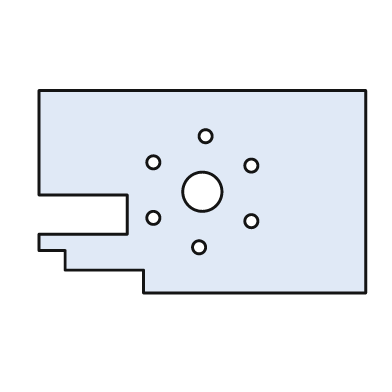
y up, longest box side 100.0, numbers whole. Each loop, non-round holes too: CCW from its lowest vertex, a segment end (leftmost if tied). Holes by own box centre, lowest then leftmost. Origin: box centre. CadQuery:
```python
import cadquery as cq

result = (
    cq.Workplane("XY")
    .moveTo(-18.0, -31.0)
    .lineTo(50.0, -31.0)
    .lineTo(50.0, 31.0)
    .lineTo(-50.0, 31.0)
    .lineTo(-50.0, -1.0)
    .lineTo(-23.0, -1.0)
    .lineTo(-23.0, -13.0)
    .lineTo(-50.0, -13.0)
    .lineTo(-50.0, -18.0)
    .lineTo(-42.0, -18.0)
    .lineTo(-42.0, -24.0)
    .lineTo(-18.0, -24.0)
    .close()
    .moveTo(-1.0, -17.0)
    .circle(2.0)
    .moveTo(15.0, -9.0)
    .circle(2.0)
    .moveTo(-15.0, -8.0)
    .circle(2.0)
    .moveTo(0.0, 0.0)
    .circle(6.0)
    .moveTo(15.0, 8.0)
    .circle(2.0)
    .moveTo(-15.0, 9.0)
    .circle(2.0)
    .moveTo(1.0, 17.0)
    .circle(2.0)
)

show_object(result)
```